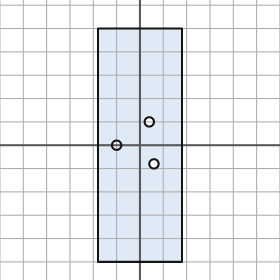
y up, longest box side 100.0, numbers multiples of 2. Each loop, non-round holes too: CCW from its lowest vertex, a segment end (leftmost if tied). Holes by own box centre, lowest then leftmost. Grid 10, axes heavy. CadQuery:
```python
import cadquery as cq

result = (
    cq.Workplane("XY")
    .moveTo(-18.0, -50.0)
    .lineTo(18.0, -50.0)
    .lineTo(18.0, 50.0)
    .lineTo(-18.0, 50.0)
    .close()
    .moveTo(6.0, -8.0)
    .circle(2.0)
    .moveTo(-10.0, 0.0)
    .circle(2.0)
    .moveTo(4.0, 10.0)
    .circle(2.0)
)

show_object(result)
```